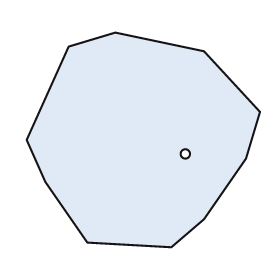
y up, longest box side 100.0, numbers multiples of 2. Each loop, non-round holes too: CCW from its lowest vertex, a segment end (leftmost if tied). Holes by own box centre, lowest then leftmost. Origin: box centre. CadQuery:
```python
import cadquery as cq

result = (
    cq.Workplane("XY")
    .moveTo(12.0, -46.0)
    .lineTo(26.0, -34.0)
    .lineTo(44.0, -8.0)
    .lineTo(50.0, 12.0)
    .lineTo(26.0, 38.0)
    .lineTo(-12.0, 46.0)
    .lineTo(-32.0, 40.0)
    .lineTo(-50.0, 0.0)
    .lineTo(-42.0, -18.0)
    .lineTo(-24.0, -44.0)
    .close()
    .moveTo(18.0, -6.0)
    .circle(2.0)
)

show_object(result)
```